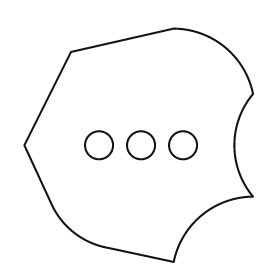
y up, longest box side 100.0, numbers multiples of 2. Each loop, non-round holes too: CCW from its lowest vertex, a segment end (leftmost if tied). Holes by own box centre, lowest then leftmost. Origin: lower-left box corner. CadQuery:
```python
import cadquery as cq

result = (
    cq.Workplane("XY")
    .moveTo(64.0, 0.0)
    .threePointArc((76.0, 20.0), (98.0, 28.0))
    .threePointArc((90.0, 50.0), (98.0, 72.0))
    .threePointArc((86.0, 92.0), (64.0, 100.0))
    .lineTo(20.0, 90.0)
    .lineTo(0.0, 50.0)
    .lineTo(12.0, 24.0)
    .threePointArc((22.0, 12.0), (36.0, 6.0))
    .close()
    .moveTo(32.0, 50.0)
    .circle(6.0)
    .moveTo(50.0, 50.0)
    .circle(6.0)
    .moveTo(68.0, 50.0)
    .circle(6.0)
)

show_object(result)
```